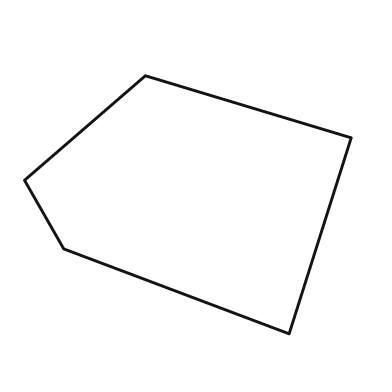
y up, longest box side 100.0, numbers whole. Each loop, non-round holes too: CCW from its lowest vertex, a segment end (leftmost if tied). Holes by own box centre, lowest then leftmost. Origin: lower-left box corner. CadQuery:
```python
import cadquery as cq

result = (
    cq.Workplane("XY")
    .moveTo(81.0, 0.0)
    .lineTo(100.0, 60.0)
    .lineTo(37.0, 79.0)
    .lineTo(0.0, 47.0)
    .lineTo(12.0, 26.0)
    .close()
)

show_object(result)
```